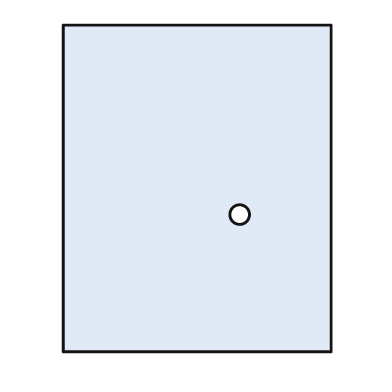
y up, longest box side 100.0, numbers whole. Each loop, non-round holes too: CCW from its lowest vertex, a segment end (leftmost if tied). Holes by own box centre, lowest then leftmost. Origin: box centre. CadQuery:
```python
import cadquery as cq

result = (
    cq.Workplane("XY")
    .moveTo(-41.0, -50.0)
    .lineTo(41.0, -50.0)
    .lineTo(41.0, 50.0)
    .lineTo(-41.0, 50.0)
    .close()
    .moveTo(13.0, -8.0)
    .circle(3.0)
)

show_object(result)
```